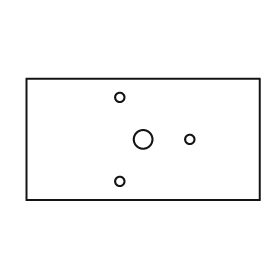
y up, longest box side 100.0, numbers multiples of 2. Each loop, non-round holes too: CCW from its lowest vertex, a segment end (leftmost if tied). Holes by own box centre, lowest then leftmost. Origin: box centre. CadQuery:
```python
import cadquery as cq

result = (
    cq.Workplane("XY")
    .moveTo(-50.0, -26.0)
    .lineTo(50.0, -26.0)
    .lineTo(50.0, 26.0)
    .lineTo(-50.0, 26.0)
    .close()
    .moveTo(-10.0, -18.0)
    .circle(2.0)
    .moveTo(0.0, 0.0)
    .circle(4.0)
    .moveTo(20.0, 0.0)
    .circle(2.0)
    .moveTo(-10.0, 18.0)
    .circle(2.0)
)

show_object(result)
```